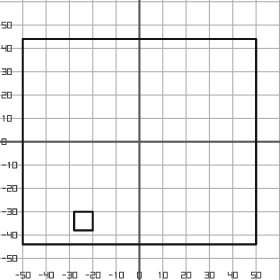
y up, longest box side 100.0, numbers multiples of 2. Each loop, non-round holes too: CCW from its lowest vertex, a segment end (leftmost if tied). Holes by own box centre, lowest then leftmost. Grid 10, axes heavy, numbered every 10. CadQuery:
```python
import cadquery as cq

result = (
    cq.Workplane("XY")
    .moveTo(-50.0, -44.0)
    .lineTo(50.0, -44.0)
    .lineTo(50.0, 44.0)
    .lineTo(-50.0, 44.0)
    .close()
    .moveTo(-28.0, -38.0)
    .lineTo(-20.0, -38.0)
    .lineTo(-20.0, -30.0)
    .lineTo(-28.0, -30.0)
    .close()
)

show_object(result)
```